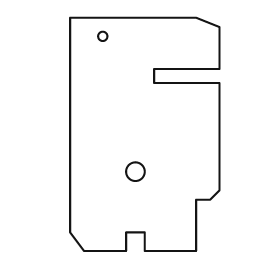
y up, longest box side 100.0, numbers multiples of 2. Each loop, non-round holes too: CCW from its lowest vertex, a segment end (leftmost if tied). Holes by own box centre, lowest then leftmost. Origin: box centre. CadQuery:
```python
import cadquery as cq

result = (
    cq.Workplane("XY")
    .moveTo(-26.0, -50.0)
    .lineTo(-8.0, -50.0)
    .lineTo(-8.0, -42.0)
    .lineTo(0.0, -42.0)
    .lineTo(0.0, -50.0)
    .lineTo(22.0, -50.0)
    .lineTo(22.0, -28.0)
    .lineTo(28.0, -28.0)
    .lineTo(32.0, -24.0)
    .lineTo(32.0, 22.0)
    .lineTo(4.0, 22.0)
    .lineTo(4.0, 28.0)
    .lineTo(32.0, 28.0)
    .lineTo(32.0, 46.0)
    .lineTo(22.0, 50.0)
    .lineTo(-32.0, 50.0)
    .lineTo(-32.0, -42.0)
    .close()
    .moveTo(-4.0, -16.0)
    .circle(4.0)
    .moveTo(-18.0, 42.0)
    .circle(2.0)
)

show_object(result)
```